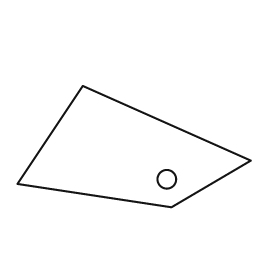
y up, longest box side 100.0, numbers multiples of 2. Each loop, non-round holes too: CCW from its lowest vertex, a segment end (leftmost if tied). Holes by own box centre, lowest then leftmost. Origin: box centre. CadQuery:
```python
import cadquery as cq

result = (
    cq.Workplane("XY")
    .moveTo(16.0, -26.0)
    .lineTo(50.0, -6.0)
    .lineTo(-22.0, 26.0)
    .lineTo(-50.0, -16.0)
    .close()
    .moveTo(14.0, -14.0)
    .circle(4.0)
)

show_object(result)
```